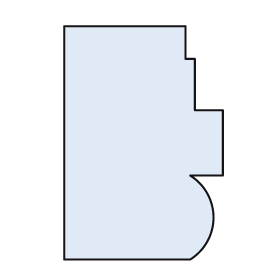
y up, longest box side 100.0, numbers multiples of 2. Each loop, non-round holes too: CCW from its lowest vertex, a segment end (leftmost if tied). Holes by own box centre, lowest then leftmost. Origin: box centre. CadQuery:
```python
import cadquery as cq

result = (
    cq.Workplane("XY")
    .moveTo(-34.0, -50.0)
    .lineTo(20.0, -50.0)
    .threePointArc((30.0, -32.0), (20.0, -14.0))
    .lineTo(34.0, -14.0)
    .lineTo(34.0, 14.0)
    .lineTo(22.0, 14.0)
    .lineTo(22.0, 36.0)
    .lineTo(18.0, 36.0)
    .lineTo(18.0, 50.0)
    .lineTo(-34.0, 50.0)
    .close()
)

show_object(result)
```